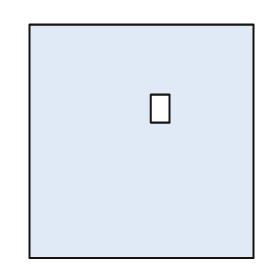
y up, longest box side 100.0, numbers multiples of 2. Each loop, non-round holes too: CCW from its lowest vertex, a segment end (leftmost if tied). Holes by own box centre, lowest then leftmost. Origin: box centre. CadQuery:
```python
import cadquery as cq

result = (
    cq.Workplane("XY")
    .moveTo(-48.0, -50.0)
    .lineTo(48.0, -50.0)
    .lineTo(48.0, 50.0)
    .lineTo(-48.0, 50.0)
    .close()
    .moveTo(4.0, 8.0)
    .lineTo(12.0, 8.0)
    .lineTo(12.0, 20.0)
    .lineTo(4.0, 20.0)
    .close()
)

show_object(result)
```